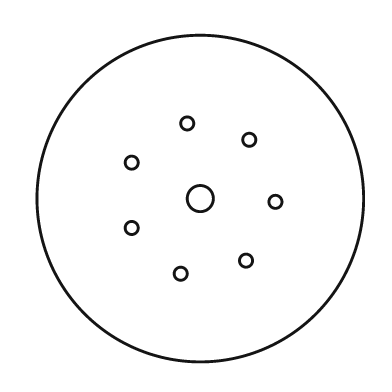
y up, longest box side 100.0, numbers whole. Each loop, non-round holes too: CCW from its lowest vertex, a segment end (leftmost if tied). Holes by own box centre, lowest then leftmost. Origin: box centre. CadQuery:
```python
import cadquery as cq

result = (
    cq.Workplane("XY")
    .moveTo(0.0, 0.0)
    .circle(50.0)
    .moveTo(-6.0, -23.0)
    .circle(2.0)
    .moveTo(14.0, -19.0)
    .circle(2.0)
    .moveTo(-21.0, -9.0)
    .circle(2.0)
    .moveTo(23.0, -1.0)
    .circle(2.0)
    .moveTo(0.0, 0.0)
    .circle(4.0)
    .moveTo(-21.0, 11.0)
    .circle(2.0)
    .moveTo(15.0, 18.0)
    .circle(2.0)
    .moveTo(-4.0, 23.0)
    .circle(2.0)
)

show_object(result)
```